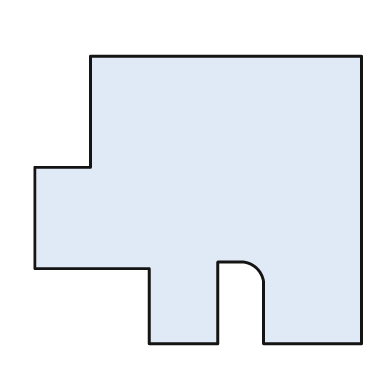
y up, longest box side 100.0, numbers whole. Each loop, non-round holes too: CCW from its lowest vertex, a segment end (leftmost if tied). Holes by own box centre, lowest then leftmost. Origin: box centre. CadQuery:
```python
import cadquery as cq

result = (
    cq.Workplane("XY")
    .moveTo(-15.0, -44.0)
    .lineTo(6.0, -44.0)
    .lineTo(6.0, -19.0)
    .lineTo(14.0, -19.0)
    .threePointArc((18.0, -21.0), (20.0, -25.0))
    .lineTo(20.0, -44.0)
    .lineTo(50.0, -44.0)
    .lineTo(50.0, 44.0)
    .lineTo(-33.0, 44.0)
    .lineTo(-33.0, 10.0)
    .lineTo(-50.0, 10.0)
    .lineTo(-50.0, -21.0)
    .lineTo(-15.0, -21.0)
    .close()
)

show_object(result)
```